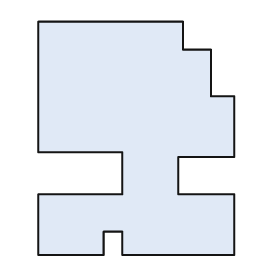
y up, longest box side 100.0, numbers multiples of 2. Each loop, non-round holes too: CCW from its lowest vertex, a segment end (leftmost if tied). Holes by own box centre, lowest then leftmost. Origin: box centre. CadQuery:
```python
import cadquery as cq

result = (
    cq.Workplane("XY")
    .moveTo(-42.0, -50.0)
    .lineTo(-14.0, -50.0)
    .lineTo(-14.0, -40.0)
    .lineTo(-6.0, -40.0)
    .lineTo(-6.0, -50.0)
    .lineTo(42.0, -50.0)
    .lineTo(42.0, -24.0)
    .lineTo(18.0, -24.0)
    .lineTo(18.0, -8.0)
    .lineTo(42.0, -8.0)
    .lineTo(42.0, 18.0)
    .lineTo(32.0, 18.0)
    .lineTo(32.0, 38.0)
    .lineTo(20.0, 38.0)
    .lineTo(20.0, 50.0)
    .lineTo(-42.0, 50.0)
    .lineTo(-42.0, -6.0)
    .lineTo(-6.0, -6.0)
    .lineTo(-6.0, -24.0)
    .lineTo(-42.0, -24.0)
    .close()
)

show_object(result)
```